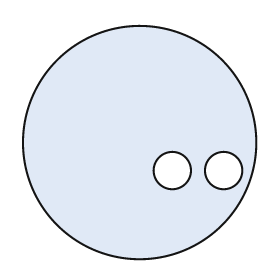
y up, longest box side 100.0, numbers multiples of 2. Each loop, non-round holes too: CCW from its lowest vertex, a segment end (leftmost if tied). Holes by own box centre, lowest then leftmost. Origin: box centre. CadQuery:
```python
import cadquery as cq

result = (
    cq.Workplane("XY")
    .moveTo(0.0, 0.0)
    .circle(50.0)
    .moveTo(14.0, -12.0)
    .circle(8.0)
    .moveTo(36.0, -12.0)
    .circle(8.0)
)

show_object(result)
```